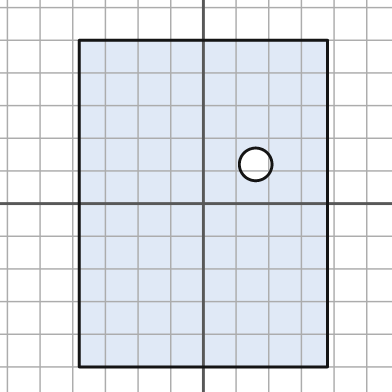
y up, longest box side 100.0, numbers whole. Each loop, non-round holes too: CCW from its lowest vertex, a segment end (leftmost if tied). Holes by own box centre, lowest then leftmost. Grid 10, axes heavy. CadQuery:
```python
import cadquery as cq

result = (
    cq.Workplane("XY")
    .moveTo(-38.0, -50.0)
    .lineTo(38.0, -50.0)
    .lineTo(38.0, 50.0)
    .lineTo(-38.0, 50.0)
    .close()
    .moveTo(16.0, 12.0)
    .circle(5.0)
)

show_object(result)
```